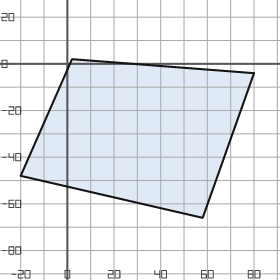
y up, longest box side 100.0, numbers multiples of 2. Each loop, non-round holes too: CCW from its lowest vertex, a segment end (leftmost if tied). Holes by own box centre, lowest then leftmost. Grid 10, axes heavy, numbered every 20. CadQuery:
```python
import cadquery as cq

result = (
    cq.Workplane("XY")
    .moveTo(58.0, -66.0)
    .lineTo(80.0, -4.0)
    .lineTo(2.0, 2.0)
    .lineTo(-20.0, -48.0)
    .close()
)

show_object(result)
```